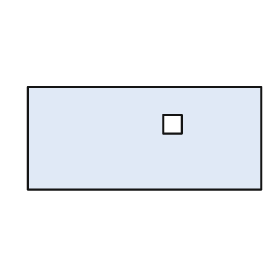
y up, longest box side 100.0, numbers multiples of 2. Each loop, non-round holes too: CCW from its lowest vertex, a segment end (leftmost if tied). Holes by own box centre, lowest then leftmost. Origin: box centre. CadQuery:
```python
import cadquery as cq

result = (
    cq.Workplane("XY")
    .moveTo(-50.0, -22.0)
    .lineTo(50.0, -22.0)
    .lineTo(50.0, 22.0)
    .lineTo(-50.0, 22.0)
    .close()
    .moveTo(8.0, 2.0)
    .lineTo(16.0, 2.0)
    .lineTo(16.0, 10.0)
    .lineTo(8.0, 10.0)
    .close()
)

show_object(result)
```